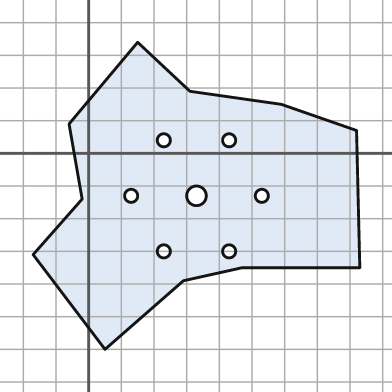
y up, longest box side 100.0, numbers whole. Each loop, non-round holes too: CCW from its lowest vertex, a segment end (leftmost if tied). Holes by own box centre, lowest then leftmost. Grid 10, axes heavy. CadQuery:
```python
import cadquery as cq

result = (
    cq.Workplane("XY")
    .moveTo(5.0, -60.0)
    .lineTo(29.0, -39.0)
    .lineTo(47.0, -35.0)
    .lineTo(83.0, -35.0)
    .lineTo(82.0, 7.0)
    .lineTo(59.0, 15.0)
    .lineTo(31.0, 19.0)
    .lineTo(15.0, 34.0)
    .lineTo(-6.0, 9.0)
    .lineTo(-2.0, -14.0)
    .lineTo(-17.0, -31.0)
    .close()
    .moveTo(23.0, -30.0)
    .circle(2.0)
    .moveTo(43.0, -30.0)
    .circle(2.0)
    .moveTo(13.0, -13.0)
    .circle(2.0)
    .moveTo(33.0, -13.0)
    .circle(3.0)
    .moveTo(53.0, -13.0)
    .circle(2.0)
    .moveTo(23.0, 4.0)
    .circle(2.0)
    .moveTo(43.0, 4.0)
    .circle(2.0)
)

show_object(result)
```